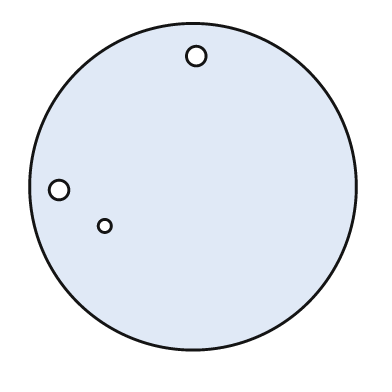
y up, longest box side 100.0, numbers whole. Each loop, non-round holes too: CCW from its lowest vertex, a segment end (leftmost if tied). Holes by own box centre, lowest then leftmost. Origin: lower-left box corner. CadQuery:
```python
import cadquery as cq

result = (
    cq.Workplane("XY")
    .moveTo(50.0, 50.0)
    .circle(50.0)
    .moveTo(23.0, 38.0)
    .circle(2.0)
    .moveTo(9.0, 49.0)
    .circle(3.0)
    .moveTo(51.0, 90.0)
    .circle(3.0)
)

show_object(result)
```